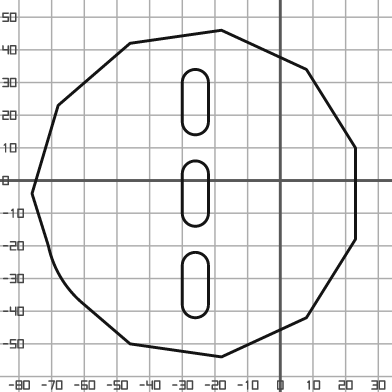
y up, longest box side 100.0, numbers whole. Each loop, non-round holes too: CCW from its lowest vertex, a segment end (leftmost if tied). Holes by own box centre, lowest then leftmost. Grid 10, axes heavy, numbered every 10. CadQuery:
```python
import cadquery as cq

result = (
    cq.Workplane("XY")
    .moveTo(-18.0, -54.0)
    .lineTo(8.0, -42.0)
    .lineTo(23.0, -18.0)
    .lineTo(23.0, 10.0)
    .lineTo(8.0, 34.0)
    .lineTo(-18.0, 46.0)
    .lineTo(-46.0, 42.0)
    .lineTo(-68.0, 23.0)
    .lineTo(-76.0, -4.0)
    .lineTo(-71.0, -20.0)
    .threePointArc((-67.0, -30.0), (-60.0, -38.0))
    .lineTo(-46.0, -50.0)
    .close()
    .moveTo(-30.0, -38.0)
    .threePointArc((-26.0, -42.0), (-22.0, -38.0))
    .lineTo(-22.0, -26.0)
    .threePointArc((-26.0, -22.0), (-30.0, -26.0))
    .close()
    .moveTo(-30.0, -10.0)
    .threePointArc((-26.0, -14.0), (-22.0, -10.0))
    .lineTo(-22.0, 2.0)
    .threePointArc((-26.0, 6.0), (-30.0, 2.0))
    .close()
    .moveTo(-30.0, 18.0)
    .threePointArc((-26.0, 14.0), (-22.0, 18.0))
    .lineTo(-22.0, 30.0)
    .threePointArc((-26.0, 34.0), (-30.0, 30.0))
    .close()
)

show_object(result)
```